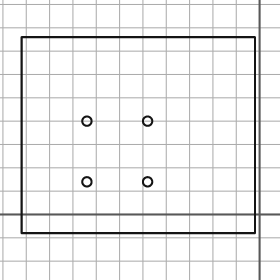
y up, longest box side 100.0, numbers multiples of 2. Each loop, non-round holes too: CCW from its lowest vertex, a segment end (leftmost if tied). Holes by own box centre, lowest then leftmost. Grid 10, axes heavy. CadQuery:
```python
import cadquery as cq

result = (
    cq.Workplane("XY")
    .moveTo(-102.0, -8.0)
    .lineTo(-2.0, -8.0)
    .lineTo(-2.0, 76.0)
    .lineTo(-102.0, 76.0)
    .close()
    .moveTo(-74.0, 14.0)
    .circle(2.0)
    .moveTo(-48.0, 14.0)
    .circle(2.0)
    .moveTo(-74.0, 40.0)
    .circle(2.0)
    .moveTo(-48.0, 40.0)
    .circle(2.0)
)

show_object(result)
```